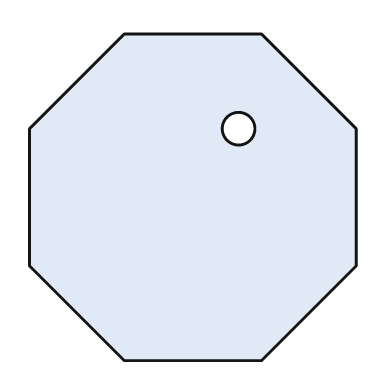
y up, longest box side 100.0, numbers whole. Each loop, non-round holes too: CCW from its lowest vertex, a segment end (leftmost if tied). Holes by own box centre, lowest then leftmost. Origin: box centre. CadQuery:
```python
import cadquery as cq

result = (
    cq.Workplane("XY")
    .moveTo(-21.0, -50.0)
    .lineTo(21.0, -50.0)
    .lineTo(50.0, -21.0)
    .lineTo(50.0, 21.0)
    .lineTo(21.0, 50.0)
    .lineTo(-21.0, 50.0)
    .lineTo(-50.0, 21.0)
    .lineTo(-50.0, -21.0)
    .close()
    .moveTo(14.0, 21.0)
    .circle(5.0)
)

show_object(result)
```